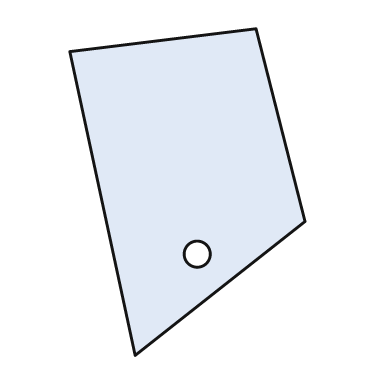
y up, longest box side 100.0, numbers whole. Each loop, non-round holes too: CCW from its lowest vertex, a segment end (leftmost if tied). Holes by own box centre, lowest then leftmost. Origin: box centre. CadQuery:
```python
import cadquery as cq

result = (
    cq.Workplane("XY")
    .moveTo(-16.0, -50.0)
    .lineTo(36.0, -9.0)
    .lineTo(21.0, 50.0)
    .lineTo(-36.0, 43.0)
    .close()
    .moveTo(3.0, -19.0)
    .circle(4.0)
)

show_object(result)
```